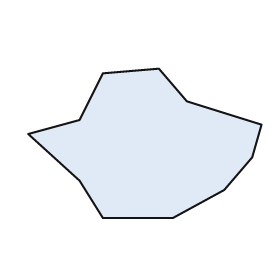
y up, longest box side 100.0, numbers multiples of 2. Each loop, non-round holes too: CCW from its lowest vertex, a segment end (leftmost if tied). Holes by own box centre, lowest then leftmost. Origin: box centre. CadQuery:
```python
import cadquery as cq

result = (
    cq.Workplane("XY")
    .moveTo(-18.0, -32.0)
    .lineTo(12.0, -32.0)
    .lineTo(34.0, -20.0)
    .lineTo(46.0, -6.0)
    .lineTo(50.0, 8.0)
    .lineTo(18.0, 18.0)
    .lineTo(6.0, 32.0)
    .lineTo(-18.0, 30.0)
    .lineTo(-28.0, 10.0)
    .lineTo(-50.0, 4.0)
    .lineTo(-28.0, -16.0)
    .close()
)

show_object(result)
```